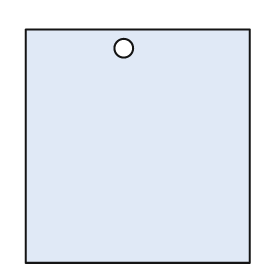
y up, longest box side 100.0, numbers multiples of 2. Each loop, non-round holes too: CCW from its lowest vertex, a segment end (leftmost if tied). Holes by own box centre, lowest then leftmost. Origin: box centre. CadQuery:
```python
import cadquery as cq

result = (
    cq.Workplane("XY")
    .moveTo(-48.0, -50.0)
    .lineTo(48.0, -50.0)
    .lineTo(48.0, 50.0)
    .lineTo(-48.0, 50.0)
    .close()
    .moveTo(-6.0, 42.0)
    .circle(4.0)
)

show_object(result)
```